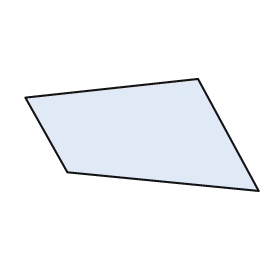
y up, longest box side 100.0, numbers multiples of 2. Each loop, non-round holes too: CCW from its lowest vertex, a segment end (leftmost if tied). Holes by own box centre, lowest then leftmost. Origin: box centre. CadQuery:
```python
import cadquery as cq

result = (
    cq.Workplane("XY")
    .moveTo(50.0, -24.0)
    .lineTo(24.0, 24.0)
    .lineTo(-50.0, 16.0)
    .lineTo(-32.0, -16.0)
    .close()
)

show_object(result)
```